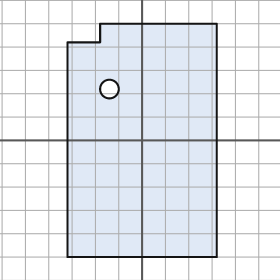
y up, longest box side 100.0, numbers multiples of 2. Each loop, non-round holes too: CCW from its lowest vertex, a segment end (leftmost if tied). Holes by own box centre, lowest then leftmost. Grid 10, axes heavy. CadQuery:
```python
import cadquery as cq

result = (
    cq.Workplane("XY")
    .moveTo(-32.0, -50.0)
    .lineTo(32.0, -50.0)
    .lineTo(32.0, 50.0)
    .lineTo(-18.0, 50.0)
    .lineTo(-18.0, 42.0)
    .lineTo(-32.0, 42.0)
    .close()
    .moveTo(-14.0, 22.0)
    .circle(4.0)
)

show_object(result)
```